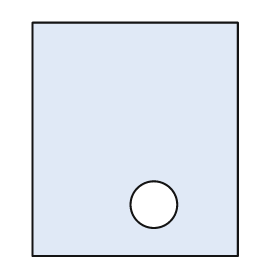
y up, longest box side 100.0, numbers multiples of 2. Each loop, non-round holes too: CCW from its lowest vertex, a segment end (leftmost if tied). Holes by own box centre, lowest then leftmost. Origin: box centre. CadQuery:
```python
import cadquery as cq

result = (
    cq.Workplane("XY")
    .moveTo(-44.0, -50.0)
    .lineTo(44.0, -50.0)
    .lineTo(44.0, 50.0)
    .lineTo(-44.0, 50.0)
    .close()
    .moveTo(8.0, -28.0)
    .circle(10.0)
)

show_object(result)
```